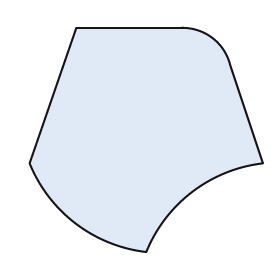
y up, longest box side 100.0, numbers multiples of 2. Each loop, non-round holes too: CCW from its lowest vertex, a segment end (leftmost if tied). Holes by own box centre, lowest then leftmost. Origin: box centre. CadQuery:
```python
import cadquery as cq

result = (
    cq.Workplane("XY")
    .moveTo(0.0, -48.0)
    .threePointArc((20.0, -22.0), (50.0, -10.0))
    .lineTo(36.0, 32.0)
    .threePointArc((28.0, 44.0), (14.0, 48.0))
    .lineTo(-30.0, 48.0)
    .lineTo(-50.0, -10.0)
    .threePointArc((-30.0, -36.0), (0.0, -48.0))
    .close()
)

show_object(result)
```